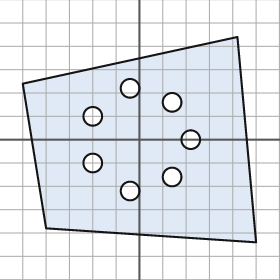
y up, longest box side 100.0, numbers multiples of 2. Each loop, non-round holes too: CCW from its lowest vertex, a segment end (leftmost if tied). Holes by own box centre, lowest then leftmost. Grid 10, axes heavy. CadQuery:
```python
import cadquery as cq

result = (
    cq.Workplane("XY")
    .moveTo(50.0, -44.0)
    .lineTo(42.0, 44.0)
    .lineTo(-50.0, 24.0)
    .lineTo(-40.0, -38.0)
    .close()
    .moveTo(-4.0, -22.0)
    .circle(4.0)
    .moveTo(14.0, -16.0)
    .circle(4.0)
    .moveTo(-20.0, -10.0)
    .circle(4.0)
    .moveTo(22.0, 0.0)
    .circle(4.0)
    .moveTo(-20.0, 10.0)
    .circle(4.0)
    .moveTo(14.0, 16.0)
    .circle(4.0)
    .moveTo(-4.0, 22.0)
    .circle(4.0)
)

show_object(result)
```